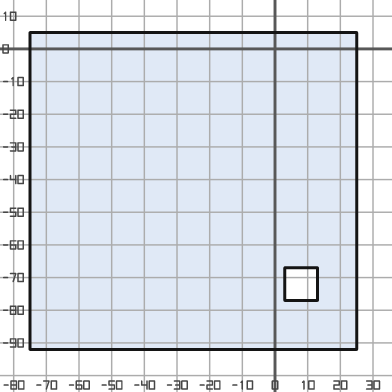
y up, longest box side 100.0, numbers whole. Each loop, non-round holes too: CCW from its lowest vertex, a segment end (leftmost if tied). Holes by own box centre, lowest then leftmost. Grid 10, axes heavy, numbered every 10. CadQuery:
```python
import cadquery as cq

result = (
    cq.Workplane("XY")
    .moveTo(-75.0, -92.0)
    .lineTo(25.0, -92.0)
    .lineTo(25.0, 5.0)
    .lineTo(-75.0, 5.0)
    .close()
    .moveTo(3.0, -77.0)
    .lineTo(13.0, -77.0)
    .lineTo(13.0, -67.0)
    .lineTo(3.0, -67.0)
    .close()
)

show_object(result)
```